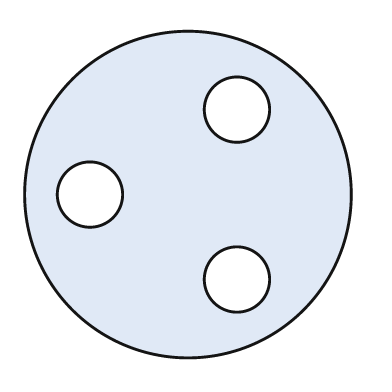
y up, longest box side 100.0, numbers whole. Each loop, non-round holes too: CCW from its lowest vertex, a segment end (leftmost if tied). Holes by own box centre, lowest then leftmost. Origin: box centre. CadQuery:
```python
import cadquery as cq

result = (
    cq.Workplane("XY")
    .moveTo(0.0, 0.0)
    .circle(50.0)
    .moveTo(15.0, -26.0)
    .circle(10.0)
    .moveTo(-30.0, 0.0)
    .circle(10.0)
    .moveTo(15.0, 26.0)
    .circle(10.0)
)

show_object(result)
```